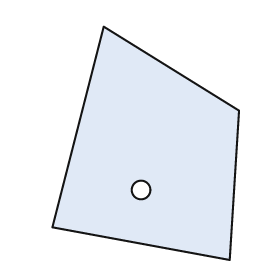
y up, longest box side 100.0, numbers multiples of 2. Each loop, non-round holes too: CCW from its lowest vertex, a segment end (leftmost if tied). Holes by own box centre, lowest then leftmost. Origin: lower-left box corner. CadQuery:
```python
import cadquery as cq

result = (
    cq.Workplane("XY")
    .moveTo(76.0, 0.0)
    .lineTo(80.0, 64.0)
    .lineTo(22.0, 100.0)
    .lineTo(0.0, 14.0)
    .close()
    .moveTo(38.0, 30.0)
    .circle(4.0)
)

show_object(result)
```